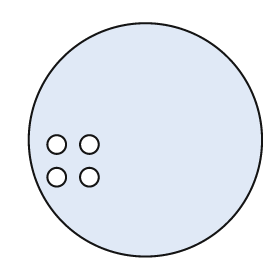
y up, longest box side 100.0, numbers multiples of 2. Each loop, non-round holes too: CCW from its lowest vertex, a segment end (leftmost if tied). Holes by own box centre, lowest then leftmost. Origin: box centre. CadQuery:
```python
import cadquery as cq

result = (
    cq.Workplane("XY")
    .moveTo(0.0, 0.0)
    .circle(50.0)
    .moveTo(-38.0, -16.0)
    .circle(4.0)
    .moveTo(-24.0, -16.0)
    .circle(4.0)
    .moveTo(-38.0, -2.0)
    .circle(4.0)
    .moveTo(-24.0, -2.0)
    .circle(4.0)
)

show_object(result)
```